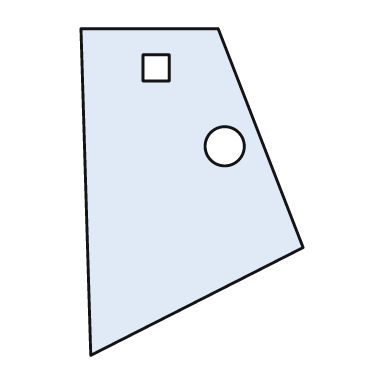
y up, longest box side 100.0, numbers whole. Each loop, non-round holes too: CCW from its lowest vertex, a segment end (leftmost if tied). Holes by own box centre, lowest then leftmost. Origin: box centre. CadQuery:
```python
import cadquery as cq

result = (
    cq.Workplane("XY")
    .moveTo(-31.0, -50.0)
    .lineTo(34.0, -17.0)
    .lineTo(8.0, 50.0)
    .lineTo(-34.0, 50.0)
    .close()
    .moveTo(10.0, 14.0)
    .circle(6.0)
    .moveTo(-15.0, 34.0)
    .lineTo(-7.0, 34.0)
    .lineTo(-7.0, 42.0)
    .lineTo(-15.0, 42.0)
    .close()
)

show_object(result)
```